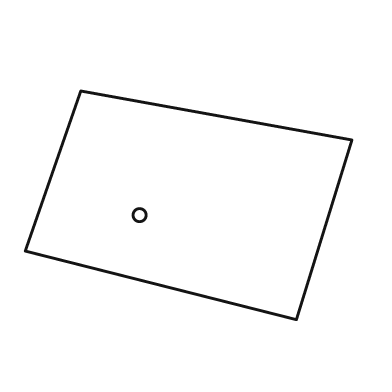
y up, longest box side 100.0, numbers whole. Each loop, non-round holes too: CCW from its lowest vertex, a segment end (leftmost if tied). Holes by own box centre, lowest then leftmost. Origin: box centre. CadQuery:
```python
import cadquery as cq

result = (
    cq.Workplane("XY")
    .moveTo(33.0, -35.0)
    .lineTo(50.0, 20.0)
    .lineTo(-33.0, 35.0)
    .lineTo(-50.0, -14.0)
    .close()
    .moveTo(-15.0, -3.0)
    .circle(2.0)
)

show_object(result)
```